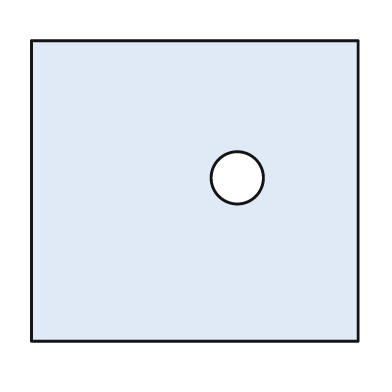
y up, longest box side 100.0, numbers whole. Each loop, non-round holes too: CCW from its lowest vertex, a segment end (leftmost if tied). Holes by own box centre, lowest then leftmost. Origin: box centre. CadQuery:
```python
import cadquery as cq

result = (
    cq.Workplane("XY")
    .moveTo(-50.0, -46.0)
    .lineTo(50.0, -46.0)
    .lineTo(50.0, 46.0)
    .lineTo(-50.0, 46.0)
    .close()
    .moveTo(13.0, 4.0)
    .circle(8.0)
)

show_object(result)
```